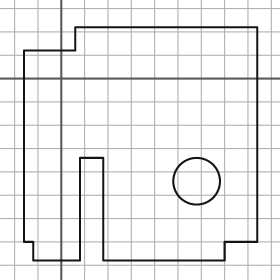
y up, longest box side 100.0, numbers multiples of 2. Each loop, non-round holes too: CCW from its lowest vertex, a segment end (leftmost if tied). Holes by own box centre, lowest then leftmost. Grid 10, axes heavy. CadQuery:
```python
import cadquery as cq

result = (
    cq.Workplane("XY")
    .moveTo(-12.0, -78.0)
    .lineTo(8.0, -78.0)
    .lineTo(8.0, -34.0)
    .lineTo(18.0, -34.0)
    .lineTo(18.0, -78.0)
    .lineTo(70.0, -78.0)
    .lineTo(70.0, -70.0)
    .lineTo(84.0, -70.0)
    .lineTo(84.0, 22.0)
    .lineTo(6.0, 22.0)
    .lineTo(6.0, 12.0)
    .lineTo(-16.0, 12.0)
    .lineTo(-16.0, -70.0)
    .lineTo(-12.0, -70.0)
    .close()
    .moveTo(58.0, -44.0)
    .circle(10.0)
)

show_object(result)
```